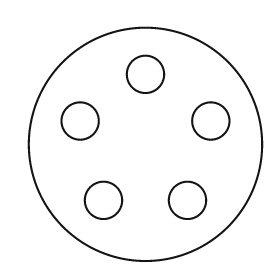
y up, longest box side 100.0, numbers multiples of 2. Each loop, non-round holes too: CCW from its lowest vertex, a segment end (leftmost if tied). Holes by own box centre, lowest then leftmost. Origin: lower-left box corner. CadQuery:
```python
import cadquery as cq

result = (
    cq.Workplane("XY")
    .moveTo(50.0, 50.0)
    .circle(50.0)
    .moveTo(32.0, 26.0)
    .circle(8.0)
    .moveTo(68.0, 26.0)
    .circle(8.0)
    .moveTo(22.0, 60.0)
    .circle(8.0)
    .moveTo(78.0, 60.0)
    .circle(8.0)
    .moveTo(50.0, 80.0)
    .circle(8.0)
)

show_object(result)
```